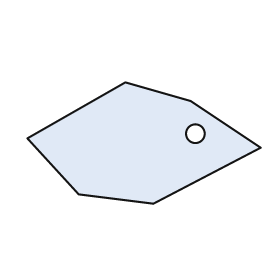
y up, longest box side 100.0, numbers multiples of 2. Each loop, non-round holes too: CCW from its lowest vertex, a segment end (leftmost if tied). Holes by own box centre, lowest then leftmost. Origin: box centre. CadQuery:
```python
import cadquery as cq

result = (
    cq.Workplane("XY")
    .moveTo(4.0, -26.0)
    .lineTo(50.0, -2.0)
    .lineTo(20.0, 18.0)
    .lineTo(-8.0, 26.0)
    .lineTo(-50.0, 2.0)
    .lineTo(-28.0, -22.0)
    .close()
    .moveTo(22.0, 4.0)
    .circle(4.0)
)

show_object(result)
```